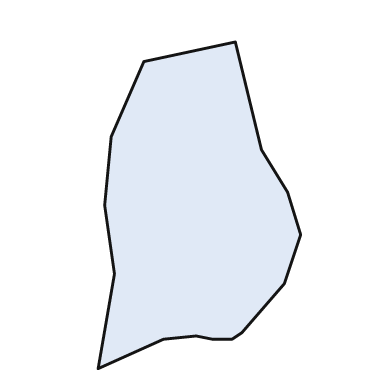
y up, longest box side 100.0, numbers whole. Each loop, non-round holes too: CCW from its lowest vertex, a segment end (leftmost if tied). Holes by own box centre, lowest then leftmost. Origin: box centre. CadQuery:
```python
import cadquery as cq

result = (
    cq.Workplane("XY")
    .moveTo(-31.0, -50.0)
    .lineTo(-11.0, -41.0)
    .lineTo(-1.0, -40.0)
    .lineTo(4.0, -41.0)
    .lineTo(10.0, -41.0)
    .lineTo(13.0, -39.0)
    .lineTo(26.0, -24.0)
    .lineTo(31.0, -9.0)
    .lineTo(27.0, 4.0)
    .lineTo(19.0, 17.0)
    .lineTo(11.0, 50.0)
    .lineTo(-17.0, 44.0)
    .lineTo(-27.0, 21.0)
    .lineTo(-29.0, 0.0)
    .lineTo(-26.0, -21.0)
    .close()
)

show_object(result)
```